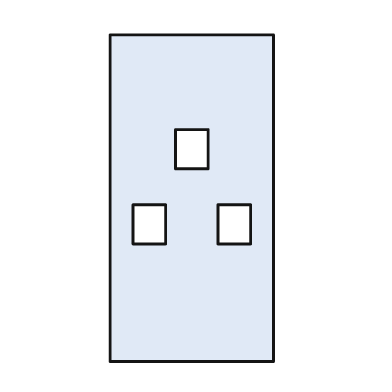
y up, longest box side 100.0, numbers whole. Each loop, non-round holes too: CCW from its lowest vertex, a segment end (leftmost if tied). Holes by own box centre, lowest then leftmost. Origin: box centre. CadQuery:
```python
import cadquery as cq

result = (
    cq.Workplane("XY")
    .moveTo(-25.0, -50.0)
    .lineTo(25.0, -50.0)
    .lineTo(25.0, 50.0)
    .lineTo(-25.0, 50.0)
    .close()
    .moveTo(-18.0, -14.0)
    .lineTo(-8.0, -14.0)
    .lineTo(-8.0, -2.0)
    .lineTo(-18.0, -2.0)
    .close()
    .moveTo(8.0, -14.0)
    .lineTo(18.0, -14.0)
    .lineTo(18.0, -2.0)
    .lineTo(8.0, -2.0)
    .close()
    .moveTo(-5.0, 9.0)
    .lineTo(5.0, 9.0)
    .lineTo(5.0, 21.0)
    .lineTo(-5.0, 21.0)
    .close()
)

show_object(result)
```